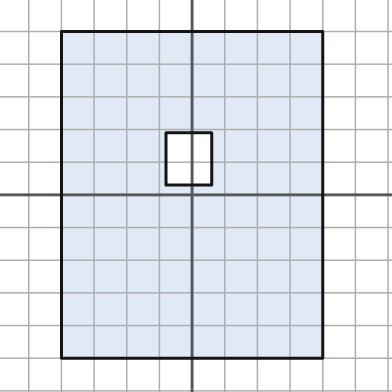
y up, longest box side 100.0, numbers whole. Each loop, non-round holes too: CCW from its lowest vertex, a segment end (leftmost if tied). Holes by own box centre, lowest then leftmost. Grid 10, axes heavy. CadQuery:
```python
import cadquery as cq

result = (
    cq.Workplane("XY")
    .moveTo(-40.0, -50.0)
    .lineTo(40.0, -50.0)
    .lineTo(40.0, 50.0)
    .lineTo(-40.0, 50.0)
    .close()
    .moveTo(-8.0, 3.0)
    .lineTo(6.0, 3.0)
    .lineTo(6.0, 19.0)
    .lineTo(-8.0, 19.0)
    .close()
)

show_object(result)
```